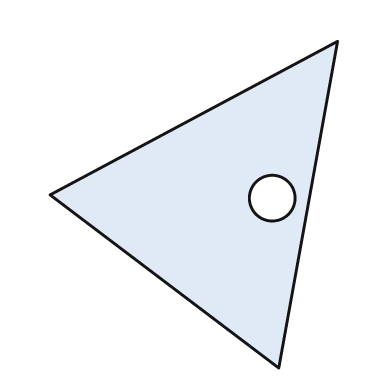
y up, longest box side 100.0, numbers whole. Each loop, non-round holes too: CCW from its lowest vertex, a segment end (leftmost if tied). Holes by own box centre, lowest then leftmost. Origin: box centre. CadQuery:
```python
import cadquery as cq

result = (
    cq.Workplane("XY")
    .moveTo(26.0, -50.0)
    .lineTo(44.0, 50.0)
    .lineTo(-44.0, 3.0)
    .close()
    .moveTo(24.0, 2.0)
    .circle(7.0)
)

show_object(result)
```